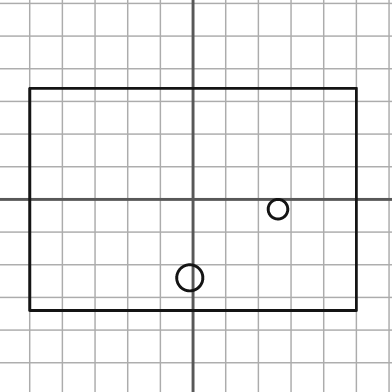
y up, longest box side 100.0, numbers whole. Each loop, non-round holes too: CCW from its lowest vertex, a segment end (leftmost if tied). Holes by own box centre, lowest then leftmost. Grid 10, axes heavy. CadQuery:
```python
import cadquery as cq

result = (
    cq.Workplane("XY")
    .moveTo(-50.0, -34.0)
    .lineTo(50.0, -34.0)
    .lineTo(50.0, 34.0)
    .lineTo(-50.0, 34.0)
    .close()
    .moveTo(-1.0, -24.0)
    .circle(4.0)
    .moveTo(26.0, -3.0)
    .circle(3.0)
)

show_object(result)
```